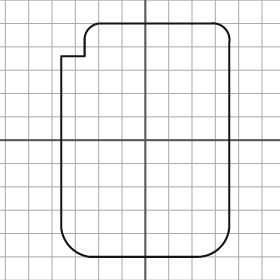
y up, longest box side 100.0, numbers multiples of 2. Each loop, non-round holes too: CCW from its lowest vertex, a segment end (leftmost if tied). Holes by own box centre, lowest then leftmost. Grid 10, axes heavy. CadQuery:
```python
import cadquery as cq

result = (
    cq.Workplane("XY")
    .moveTo(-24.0, -50.0)
    .lineTo(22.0, -50.0)
    .threePointArc((32.0, -46.0), (36.0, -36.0))
    .lineTo(36.0, 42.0)
    .threePointArc((34.0, 48.0), (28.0, 50.0))
    .lineTo(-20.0, 50.0)
    .threePointArc((-24.0, 48.0), (-26.0, 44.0))
    .lineTo(-26.0, 36.0)
    .lineTo(-36.0, 36.0)
    .lineTo(-36.0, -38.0)
    .threePointArc((-32.0, -46.0), (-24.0, -50.0))
    .close()
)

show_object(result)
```